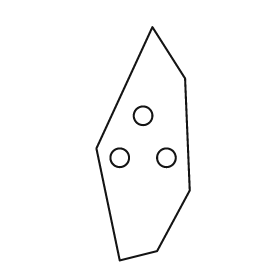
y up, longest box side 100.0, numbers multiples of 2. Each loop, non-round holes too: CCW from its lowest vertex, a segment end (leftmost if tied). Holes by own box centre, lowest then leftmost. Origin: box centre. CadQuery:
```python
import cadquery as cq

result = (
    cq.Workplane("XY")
    .moveTo(-10.0, -50.0)
    .lineTo(6.0, -46.0)
    .lineTo(20.0, -20.0)
    .lineTo(18.0, 28.0)
    .lineTo(4.0, 50.0)
    .lineTo(-20.0, -2.0)
    .close()
    .moveTo(-10.0, -6.0)
    .circle(4.0)
    .moveTo(10.0, -6.0)
    .circle(4.0)
    .moveTo(0.0, 12.0)
    .circle(4.0)
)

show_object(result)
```